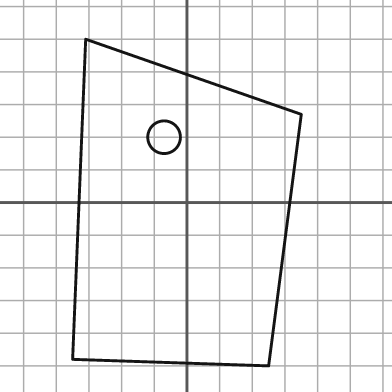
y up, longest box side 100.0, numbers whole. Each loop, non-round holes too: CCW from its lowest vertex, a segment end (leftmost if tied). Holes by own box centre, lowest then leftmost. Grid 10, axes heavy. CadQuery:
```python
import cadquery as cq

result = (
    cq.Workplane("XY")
    .moveTo(25.0, -50.0)
    .lineTo(35.0, 27.0)
    .lineTo(-31.0, 50.0)
    .lineTo(-35.0, -48.0)
    .close()
    .moveTo(-7.0, 20.0)
    .circle(5.0)
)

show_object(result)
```